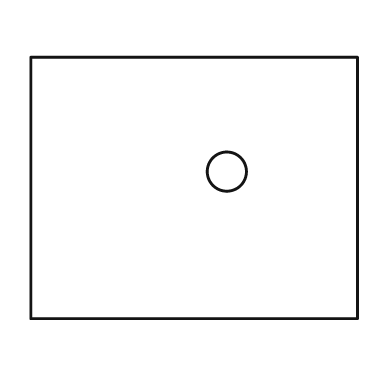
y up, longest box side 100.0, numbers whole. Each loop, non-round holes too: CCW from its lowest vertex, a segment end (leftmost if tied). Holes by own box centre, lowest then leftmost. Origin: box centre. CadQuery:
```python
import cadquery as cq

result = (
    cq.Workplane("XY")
    .moveTo(-50.0, -40.0)
    .lineTo(50.0, -40.0)
    .lineTo(50.0, 40.0)
    .lineTo(-50.0, 40.0)
    .close()
    .moveTo(10.0, 5.0)
    .circle(6.0)
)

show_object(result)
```